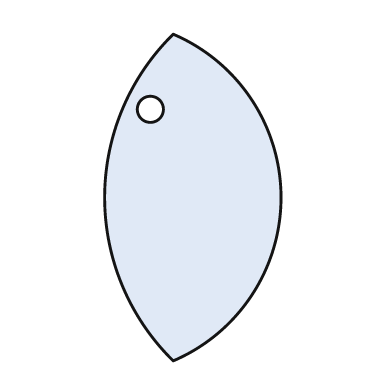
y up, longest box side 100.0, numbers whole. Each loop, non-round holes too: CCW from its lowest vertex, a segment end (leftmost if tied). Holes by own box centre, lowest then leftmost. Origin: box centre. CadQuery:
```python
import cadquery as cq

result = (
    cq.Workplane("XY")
    .moveTo(-6.0, -50.0)
    .threePointArc((27.0, 0.0), (-6.0, 50.0))
    .threePointArc((-27.0, 0.0), (-6.0, -50.0))
    .close()
    .moveTo(-13.0, 27.0)
    .circle(4.0)
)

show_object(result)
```